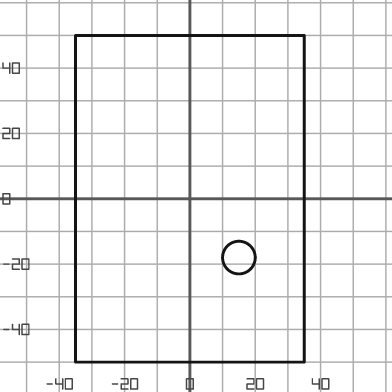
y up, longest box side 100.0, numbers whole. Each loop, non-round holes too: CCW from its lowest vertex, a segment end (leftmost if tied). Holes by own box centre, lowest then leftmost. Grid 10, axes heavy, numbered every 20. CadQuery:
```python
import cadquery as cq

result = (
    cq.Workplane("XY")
    .moveTo(-35.0, -50.0)
    .lineTo(35.0, -50.0)
    .lineTo(35.0, 50.0)
    .lineTo(-35.0, 50.0)
    .close()
    .moveTo(15.0, -18.0)
    .circle(5.0)
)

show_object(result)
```